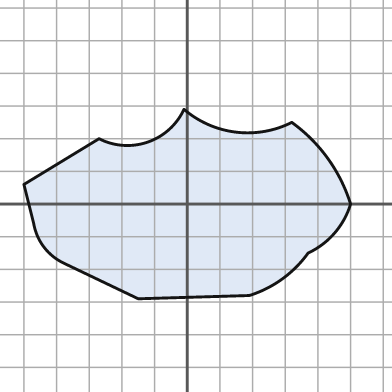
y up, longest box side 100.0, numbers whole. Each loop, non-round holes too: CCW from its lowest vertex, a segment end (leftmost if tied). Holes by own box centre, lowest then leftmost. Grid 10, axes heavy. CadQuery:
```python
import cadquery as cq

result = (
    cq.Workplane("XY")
    .moveTo(-15.0, -29.0)
    .lineTo(19.0, -28.0)
    .threePointArc((29.0, -23.0), (37.0, -15.0))
    .threePointArc((45.0, -9.0), (50.0, 0.0))
    .threePointArc((43.0, 14.0), (32.0, 25.0))
    .threePointArc((15.0, 22.0), (-1.0, 29.0))
    .threePointArc((-12.0, 19.0), (-27.0, 20.0))
    .lineTo(-50.0, 6.0)
    .lineTo(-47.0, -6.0)
    .threePointArc((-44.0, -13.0), (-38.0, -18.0))
    .close()
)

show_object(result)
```